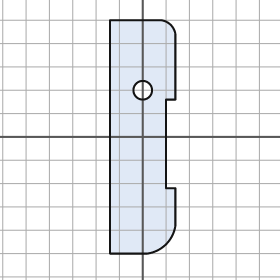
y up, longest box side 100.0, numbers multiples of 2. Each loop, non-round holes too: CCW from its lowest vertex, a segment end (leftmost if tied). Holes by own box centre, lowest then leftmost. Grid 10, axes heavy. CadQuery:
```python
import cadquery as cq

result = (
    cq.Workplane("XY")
    .moveTo(-14.0, -50.0)
    .lineTo(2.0, -50.0)
    .threePointArc((10.0, -46.0), (14.0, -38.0))
    .lineTo(14.0, -22.0)
    .lineTo(10.0, -22.0)
    .lineTo(10.0, 16.0)
    .lineTo(14.0, 16.0)
    .lineTo(14.0, 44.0)
    .threePointArc((12.0, 48.0), (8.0, 50.0))
    .lineTo(-14.0, 50.0)
    .close()
    .moveTo(0.0, 20.0)
    .circle(4.0)
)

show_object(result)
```